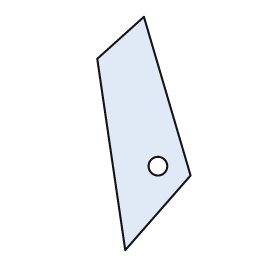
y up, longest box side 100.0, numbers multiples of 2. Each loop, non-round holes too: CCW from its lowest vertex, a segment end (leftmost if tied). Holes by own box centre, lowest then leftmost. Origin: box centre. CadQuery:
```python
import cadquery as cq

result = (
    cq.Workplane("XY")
    .moveTo(-8.0, -50.0)
    .lineTo(20.0, -18.0)
    .lineTo(0.0, 50.0)
    .lineTo(-20.0, 32.0)
    .close()
    .moveTo(6.0, -14.0)
    .circle(4.0)
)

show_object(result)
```